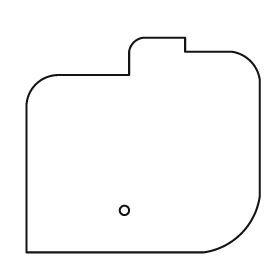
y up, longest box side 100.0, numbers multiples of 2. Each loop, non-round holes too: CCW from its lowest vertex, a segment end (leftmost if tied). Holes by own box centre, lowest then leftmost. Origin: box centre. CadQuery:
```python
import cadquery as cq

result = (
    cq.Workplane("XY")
    .moveTo(-50.0, -46.0)
    .lineTo(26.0, -46.0)
    .threePointArc((42.0, -38.0), (50.0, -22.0))
    .lineTo(50.0, 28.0)
    .threePointArc((46.0, 36.0), (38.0, 40.0))
    .lineTo(18.0, 40.0)
    .lineTo(18.0, 46.0)
    .lineTo(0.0, 46.0)
    .threePointArc((-4.0, 44.0), (-6.0, 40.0))
    .lineTo(-6.0, 30.0)
    .lineTo(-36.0, 30.0)
    .threePointArc((-46.0, 26.0), (-50.0, 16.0))
    .close()
    .moveTo(-8.0, -28.0)
    .circle(2.0)
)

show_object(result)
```